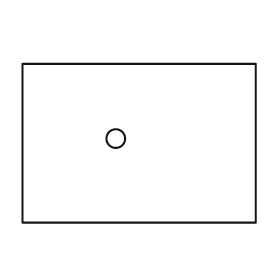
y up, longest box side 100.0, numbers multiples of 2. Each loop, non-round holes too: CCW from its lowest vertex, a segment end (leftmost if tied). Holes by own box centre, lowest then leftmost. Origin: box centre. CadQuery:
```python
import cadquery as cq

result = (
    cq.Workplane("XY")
    .moveTo(-50.0, -34.0)
    .lineTo(50.0, -34.0)
    .lineTo(50.0, 34.0)
    .lineTo(-50.0, 34.0)
    .close()
    .moveTo(-10.0, 2.0)
    .circle(4.0)
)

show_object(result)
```